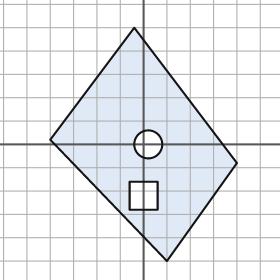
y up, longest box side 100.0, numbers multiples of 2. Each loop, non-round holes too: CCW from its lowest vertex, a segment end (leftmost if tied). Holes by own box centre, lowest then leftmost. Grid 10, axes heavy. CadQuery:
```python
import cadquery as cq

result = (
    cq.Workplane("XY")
    .moveTo(10.0, -50.0)
    .lineTo(40.0, -8.0)
    .lineTo(-4.0, 50.0)
    .lineTo(-40.0, 2.0)
    .close()
    .moveTo(-6.0, -28.0)
    .lineTo(6.0, -28.0)
    .lineTo(6.0, -16.0)
    .lineTo(-6.0, -16.0)
    .close()
    .moveTo(2.0, 0.0)
    .circle(6.0)
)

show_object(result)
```